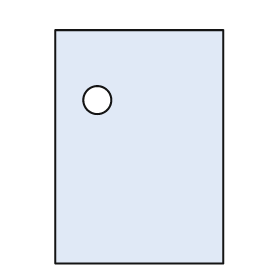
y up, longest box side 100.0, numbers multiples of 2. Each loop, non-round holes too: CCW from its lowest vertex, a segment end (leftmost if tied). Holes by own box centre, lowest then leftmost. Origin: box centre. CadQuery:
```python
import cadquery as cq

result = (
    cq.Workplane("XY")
    .moveTo(-36.0, -50.0)
    .lineTo(36.0, -50.0)
    .lineTo(36.0, 50.0)
    .lineTo(-36.0, 50.0)
    .close()
    .moveTo(-18.0, 20.0)
    .circle(6.0)
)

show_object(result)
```